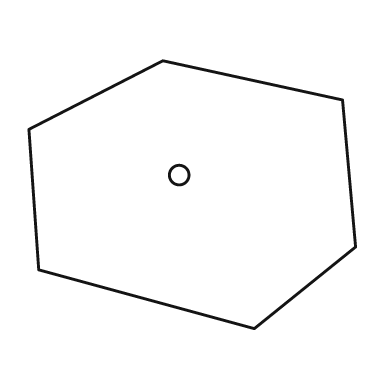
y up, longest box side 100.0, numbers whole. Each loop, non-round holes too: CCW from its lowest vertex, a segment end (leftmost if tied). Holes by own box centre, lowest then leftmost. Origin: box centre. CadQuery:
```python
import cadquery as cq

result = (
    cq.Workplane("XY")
    .moveTo(19.0, -41.0)
    .lineTo(50.0, -16.0)
    .lineTo(46.0, 29.0)
    .lineTo(-9.0, 41.0)
    .lineTo(-50.0, 20.0)
    .lineTo(-47.0, -23.0)
    .close()
    .moveTo(-4.0, 6.0)
    .circle(3.0)
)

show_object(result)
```